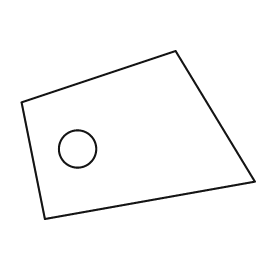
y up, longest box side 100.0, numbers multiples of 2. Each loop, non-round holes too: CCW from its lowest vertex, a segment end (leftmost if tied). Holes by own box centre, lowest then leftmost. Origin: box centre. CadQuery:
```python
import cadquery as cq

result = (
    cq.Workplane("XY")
    .moveTo(-40.0, -36.0)
    .lineTo(50.0, -20.0)
    .lineTo(16.0, 36.0)
    .lineTo(-50.0, 14.0)
    .close()
    .moveTo(-26.0, -6.0)
    .circle(8.0)
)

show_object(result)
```